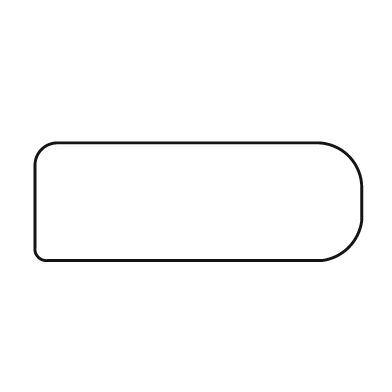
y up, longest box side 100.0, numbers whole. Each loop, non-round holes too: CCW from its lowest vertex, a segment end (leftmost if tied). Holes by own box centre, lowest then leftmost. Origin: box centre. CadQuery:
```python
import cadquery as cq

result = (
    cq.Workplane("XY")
    .moveTo(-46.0, -18.0)
    .lineTo(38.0, -18.0)
    .threePointArc((46.0, -14.0), (50.0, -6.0))
    .lineTo(50.0, 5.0)
    .threePointArc((46.0, 14.0), (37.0, 18.0))
    .lineTo(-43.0, 18.0)
    .threePointArc((-48.0, 16.0), (-50.0, 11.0))
    .lineTo(-50.0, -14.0)
    .threePointArc((-49.0, -17.0), (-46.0, -18.0))
    .close()
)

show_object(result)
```